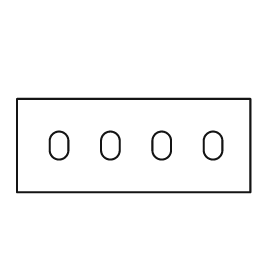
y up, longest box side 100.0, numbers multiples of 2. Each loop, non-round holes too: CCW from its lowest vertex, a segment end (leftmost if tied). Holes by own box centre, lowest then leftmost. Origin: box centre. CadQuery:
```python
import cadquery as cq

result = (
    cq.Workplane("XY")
    .moveTo(-50.0, -20.0)
    .lineTo(50.0, -20.0)
    .lineTo(50.0, 20.0)
    .lineTo(-50.0, 20.0)
    .close()
    .moveTo(-36.0, -2.0)
    .threePointArc((-32.0, -6.0), (-28.0, -2.0))
    .lineTo(-28.0, 2.0)
    .threePointArc((-32.0, 6.0), (-36.0, 2.0))
    .close()
    .moveTo(-14.0, -2.0)
    .threePointArc((-10.0, -6.0), (-6.0, -2.0))
    .lineTo(-6.0, 2.0)
    .threePointArc((-10.0, 6.0), (-14.0, 2.0))
    .close()
    .moveTo(8.0, -2.0)
    .threePointArc((12.0, -6.0), (16.0, -2.0))
    .lineTo(16.0, 2.0)
    .threePointArc((12.0, 6.0), (8.0, 2.0))
    .close()
    .moveTo(30.0, -2.0)
    .threePointArc((34.0, -6.0), (38.0, -2.0))
    .lineTo(38.0, 2.0)
    .threePointArc((34.0, 6.0), (30.0, 2.0))
    .close()
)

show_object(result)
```